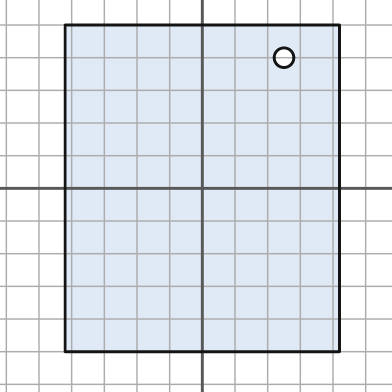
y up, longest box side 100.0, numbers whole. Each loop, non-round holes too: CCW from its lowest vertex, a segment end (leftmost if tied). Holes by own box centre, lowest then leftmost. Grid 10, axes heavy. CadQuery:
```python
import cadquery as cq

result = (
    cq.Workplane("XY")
    .moveTo(-42.0, -50.0)
    .lineTo(42.0, -50.0)
    .lineTo(42.0, 50.0)
    .lineTo(-42.0, 50.0)
    .close()
    .moveTo(25.0, 40.0)
    .circle(3.0)
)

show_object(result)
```